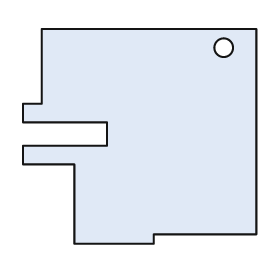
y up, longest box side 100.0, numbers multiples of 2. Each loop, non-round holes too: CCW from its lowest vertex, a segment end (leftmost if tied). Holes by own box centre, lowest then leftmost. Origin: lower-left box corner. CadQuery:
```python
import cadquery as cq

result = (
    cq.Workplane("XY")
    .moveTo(22.0, 0.0)
    .lineTo(56.0, 0.0)
    .lineTo(56.0, 4.0)
    .lineTo(100.0, 4.0)
    .lineTo(100.0, 92.0)
    .lineTo(8.0, 92.0)
    .lineTo(8.0, 60.0)
    .lineTo(0.0, 60.0)
    .lineTo(0.0, 52.0)
    .lineTo(36.0, 52.0)
    .lineTo(36.0, 42.0)
    .lineTo(0.0, 42.0)
    .lineTo(0.0, 34.0)
    .lineTo(22.0, 34.0)
    .close()
    .moveTo(86.0, 84.0)
    .circle(4.0)
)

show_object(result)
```